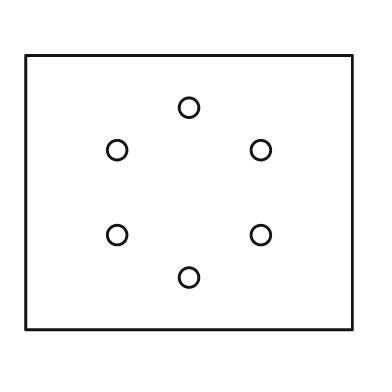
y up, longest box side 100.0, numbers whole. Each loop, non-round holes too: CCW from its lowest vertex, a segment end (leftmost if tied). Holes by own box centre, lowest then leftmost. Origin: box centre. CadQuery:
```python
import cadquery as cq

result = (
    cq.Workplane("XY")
    .moveTo(-50.0, -42.0)
    .lineTo(50.0, -42.0)
    .lineTo(50.0, 42.0)
    .lineTo(-50.0, 42.0)
    .close()
    .moveTo(0.0, -26.0)
    .circle(3.0)
    .moveTo(-22.0, -13.0)
    .circle(3.0)
    .moveTo(22.0, -13.0)
    .circle(3.0)
    .moveTo(-22.0, 13.0)
    .circle(3.0)
    .moveTo(22.0, 13.0)
    .circle(3.0)
    .moveTo(0.0, 26.0)
    .circle(3.0)
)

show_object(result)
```